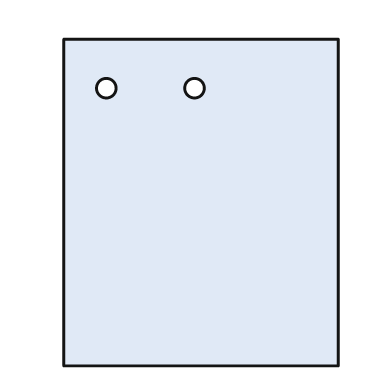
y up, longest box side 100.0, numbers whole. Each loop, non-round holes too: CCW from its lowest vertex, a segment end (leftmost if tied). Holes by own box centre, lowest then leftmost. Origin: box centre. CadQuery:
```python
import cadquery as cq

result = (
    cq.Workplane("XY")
    .moveTo(-42.0, -50.0)
    .lineTo(42.0, -50.0)
    .lineTo(42.0, 50.0)
    .lineTo(-42.0, 50.0)
    .close()
    .moveTo(-29.0, 35.0)
    .circle(3.0)
    .moveTo(-2.0, 35.0)
    .circle(3.0)
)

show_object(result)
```